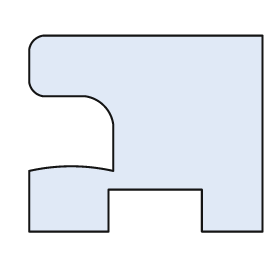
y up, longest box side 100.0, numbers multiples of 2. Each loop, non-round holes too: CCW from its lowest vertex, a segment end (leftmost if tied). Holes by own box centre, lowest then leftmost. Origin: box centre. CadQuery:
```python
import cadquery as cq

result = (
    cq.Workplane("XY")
    .moveTo(-50.0, -42.0)
    .lineTo(-16.0, -42.0)
    .lineTo(-16.0, -24.0)
    .lineTo(24.0, -24.0)
    .lineTo(24.0, -42.0)
    .lineTo(50.0, -42.0)
    .lineTo(50.0, 42.0)
    .lineTo(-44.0, 42.0)
    .threePointArc((-48.0, 40.0), (-50.0, 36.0))
    .lineTo(-50.0, 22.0)
    .threePointArc((-48.0, 18.0), (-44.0, 16.0))
    .lineTo(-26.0, 16.0)
    .threePointArc((-18.0, 12.0), (-14.0, 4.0))
    .lineTo(-14.0, -16.0)
    .threePointArc((-32.0, -14.0), (-50.0, -16.0))
    .close()
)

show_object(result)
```